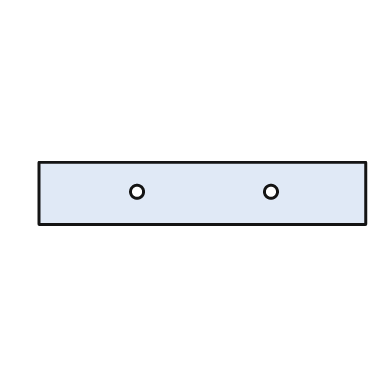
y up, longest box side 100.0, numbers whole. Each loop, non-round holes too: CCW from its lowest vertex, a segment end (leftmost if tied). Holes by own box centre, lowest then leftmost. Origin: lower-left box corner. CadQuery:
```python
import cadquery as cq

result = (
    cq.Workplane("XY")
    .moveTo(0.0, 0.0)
    .lineTo(100.0, 0.0)
    .lineTo(100.0, 19.0)
    .lineTo(0.0, 19.0)
    .close()
    .moveTo(30.0, 10.0)
    .circle(2.0)
    .moveTo(71.0, 10.0)
    .circle(2.0)
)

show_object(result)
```